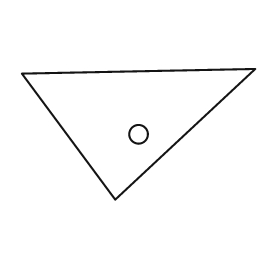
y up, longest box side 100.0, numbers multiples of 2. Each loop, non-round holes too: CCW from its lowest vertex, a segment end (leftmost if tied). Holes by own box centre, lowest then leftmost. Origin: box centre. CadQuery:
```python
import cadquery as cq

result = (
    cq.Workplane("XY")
    .moveTo(-10.0, -28.0)
    .lineTo(50.0, 28.0)
    .lineTo(-50.0, 26.0)
    .close()
    .moveTo(0.0, 0.0)
    .circle(4.0)
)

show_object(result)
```